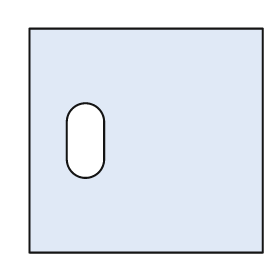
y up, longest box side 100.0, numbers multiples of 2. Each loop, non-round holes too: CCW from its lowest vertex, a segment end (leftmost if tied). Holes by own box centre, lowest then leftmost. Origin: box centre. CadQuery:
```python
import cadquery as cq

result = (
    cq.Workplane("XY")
    .moveTo(-50.0, -48.0)
    .lineTo(50.0, -48.0)
    .lineTo(50.0, 48.0)
    .lineTo(-50.0, 48.0)
    .close()
    .moveTo(-34.0, -8.0)
    .threePointArc((-26.0, -16.0), (-18.0, -8.0))
    .lineTo(-18.0, 8.0)
    .threePointArc((-26.0, 16.0), (-34.0, 8.0))
    .close()
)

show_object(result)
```